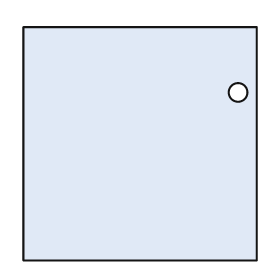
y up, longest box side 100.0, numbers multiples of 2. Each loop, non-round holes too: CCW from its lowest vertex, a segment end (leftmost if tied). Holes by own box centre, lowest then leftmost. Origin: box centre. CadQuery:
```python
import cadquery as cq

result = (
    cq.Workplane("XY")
    .moveTo(-50.0, -50.0)
    .lineTo(50.0, -50.0)
    .lineTo(50.0, 50.0)
    .lineTo(-50.0, 50.0)
    .close()
    .moveTo(42.0, 22.0)
    .circle(4.0)
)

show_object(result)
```